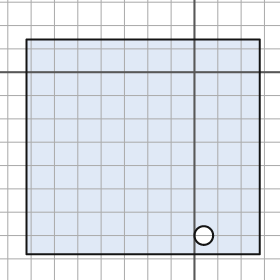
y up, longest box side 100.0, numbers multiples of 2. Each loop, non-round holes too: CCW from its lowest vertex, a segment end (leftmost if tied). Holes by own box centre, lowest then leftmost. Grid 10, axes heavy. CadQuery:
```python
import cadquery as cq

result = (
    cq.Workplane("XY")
    .moveTo(-72.0, -78.0)
    .lineTo(28.0, -78.0)
    .lineTo(28.0, 14.0)
    .lineTo(-72.0, 14.0)
    .close()
    .moveTo(4.0, -70.0)
    .circle(4.0)
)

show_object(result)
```